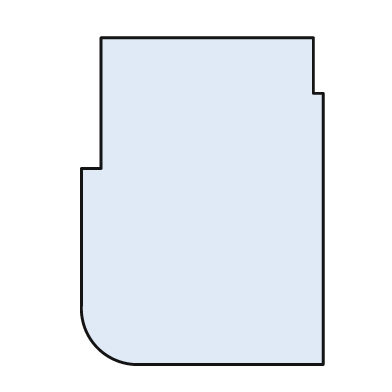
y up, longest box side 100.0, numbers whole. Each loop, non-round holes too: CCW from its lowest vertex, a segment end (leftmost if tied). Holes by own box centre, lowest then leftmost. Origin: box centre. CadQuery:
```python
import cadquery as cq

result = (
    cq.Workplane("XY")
    .moveTo(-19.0, -50.0)
    .lineTo(37.0, -50.0)
    .lineTo(37.0, 33.0)
    .lineTo(34.0, 33.0)
    .lineTo(34.0, 50.0)
    .lineTo(-31.0, 50.0)
    .lineTo(-31.0, 10.0)
    .lineTo(-37.0, 10.0)
    .lineTo(-37.0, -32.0)
    .threePointArc((-32.0, -45.0), (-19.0, -50.0))
    .close()
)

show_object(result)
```